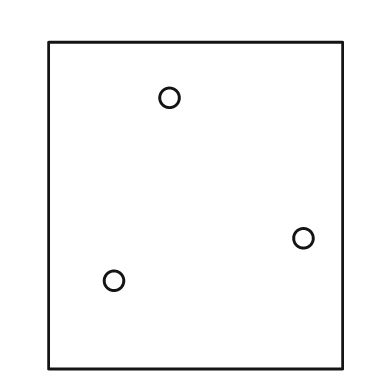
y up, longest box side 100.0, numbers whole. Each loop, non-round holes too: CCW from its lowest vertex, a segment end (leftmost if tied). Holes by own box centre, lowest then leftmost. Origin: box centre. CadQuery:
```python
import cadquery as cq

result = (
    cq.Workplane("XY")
    .moveTo(-45.0, -50.0)
    .lineTo(45.0, -50.0)
    .lineTo(45.0, 50.0)
    .lineTo(-45.0, 50.0)
    .close()
    .moveTo(-25.0, -23.0)
    .circle(3.0)
    .moveTo(33.0, -10.0)
    .circle(3.0)
    .moveTo(-8.0, 33.0)
    .circle(3.0)
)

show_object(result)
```